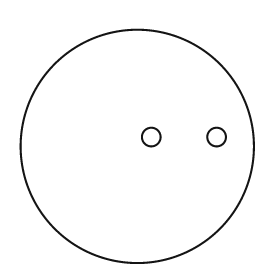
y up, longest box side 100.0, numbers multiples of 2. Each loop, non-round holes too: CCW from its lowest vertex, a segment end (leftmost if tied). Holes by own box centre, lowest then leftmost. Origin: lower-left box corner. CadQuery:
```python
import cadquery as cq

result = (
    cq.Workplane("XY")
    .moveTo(50.0, 50.0)
    .circle(50.0)
    .moveTo(56.0, 54.0)
    .circle(4.0)
    .moveTo(84.0, 54.0)
    .circle(4.0)
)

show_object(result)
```